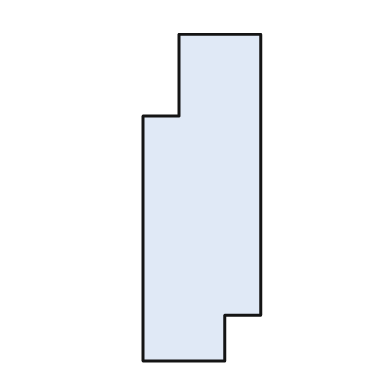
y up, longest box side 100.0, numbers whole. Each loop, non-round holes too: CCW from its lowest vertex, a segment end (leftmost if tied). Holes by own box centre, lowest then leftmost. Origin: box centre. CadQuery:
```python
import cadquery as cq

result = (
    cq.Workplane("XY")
    .moveTo(-18.0, -50.0)
    .lineTo(7.0, -50.0)
    .lineTo(7.0, -36.0)
    .lineTo(18.0, -36.0)
    .lineTo(18.0, 50.0)
    .lineTo(-7.0, 50.0)
    .lineTo(-7.0, 25.0)
    .lineTo(-18.0, 25.0)
    .close()
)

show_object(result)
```